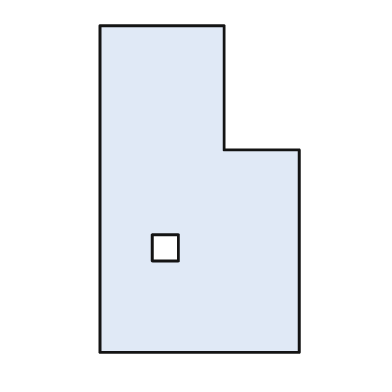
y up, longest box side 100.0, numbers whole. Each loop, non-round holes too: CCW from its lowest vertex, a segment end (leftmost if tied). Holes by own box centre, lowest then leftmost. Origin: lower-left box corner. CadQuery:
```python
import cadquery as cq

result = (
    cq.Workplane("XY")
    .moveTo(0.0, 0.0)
    .lineTo(61.0, 0.0)
    .lineTo(61.0, 62.0)
    .lineTo(38.0, 62.0)
    .lineTo(38.0, 100.0)
    .lineTo(0.0, 100.0)
    .close()
    .moveTo(16.0, 28.0)
    .lineTo(24.0, 28.0)
    .lineTo(24.0, 36.0)
    .lineTo(16.0, 36.0)
    .close()
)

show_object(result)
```